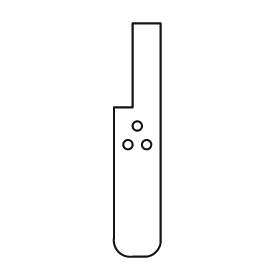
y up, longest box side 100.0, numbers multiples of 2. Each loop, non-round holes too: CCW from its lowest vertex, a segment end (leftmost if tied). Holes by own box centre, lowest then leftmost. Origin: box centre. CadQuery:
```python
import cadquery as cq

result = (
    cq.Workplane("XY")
    .moveTo(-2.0, -50.0)
    .lineTo(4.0, -50.0)
    .threePointArc((8.0, -48.0), (10.0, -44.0))
    .lineTo(10.0, 50.0)
    .lineTo(-2.0, 50.0)
    .lineTo(-2.0, 14.0)
    .lineTo(-10.0, 14.0)
    .lineTo(-10.0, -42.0)
    .threePointArc((-8.0, -48.0), (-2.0, -50.0))
    .close()
    .moveTo(-4.0, -2.0)
    .circle(2.0)
    .moveTo(4.0, -2.0)
    .circle(2.0)
    .moveTo(0.0, 6.0)
    .circle(2.0)
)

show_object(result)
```